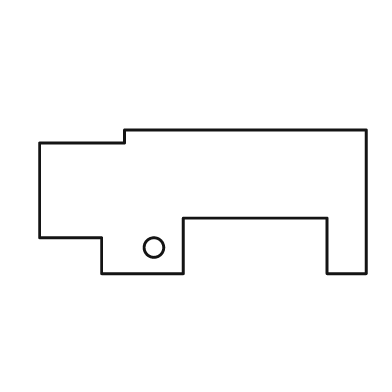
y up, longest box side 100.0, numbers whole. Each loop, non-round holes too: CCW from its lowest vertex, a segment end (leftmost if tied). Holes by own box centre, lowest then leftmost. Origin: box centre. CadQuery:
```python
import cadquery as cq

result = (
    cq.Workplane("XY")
    .moveTo(-31.0, -22.0)
    .lineTo(-6.0, -22.0)
    .lineTo(-6.0, -5.0)
    .lineTo(38.0, -5.0)
    .lineTo(38.0, -22.0)
    .lineTo(50.0, -22.0)
    .lineTo(50.0, 22.0)
    .lineTo(-24.0, 22.0)
    .lineTo(-24.0, 18.0)
    .lineTo(-50.0, 18.0)
    .lineTo(-50.0, -11.0)
    .lineTo(-31.0, -11.0)
    .close()
    .moveTo(-15.0, -14.0)
    .circle(3.0)
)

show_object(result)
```